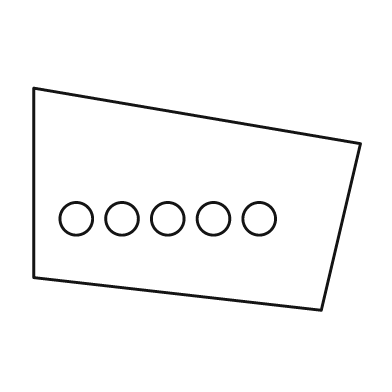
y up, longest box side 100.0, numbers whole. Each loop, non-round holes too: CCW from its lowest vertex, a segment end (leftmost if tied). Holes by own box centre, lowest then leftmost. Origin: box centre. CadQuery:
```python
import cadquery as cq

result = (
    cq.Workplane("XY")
    .moveTo(38.0, -34.0)
    .lineTo(50.0, 17.0)
    .lineTo(-50.0, 34.0)
    .lineTo(-50.0, -24.0)
    .close()
    .moveTo(-37.0, -6.0)
    .circle(5.0)
    .moveTo(-23.0, -6.0)
    .circle(5.0)
    .moveTo(-9.0, -6.0)
    .circle(5.0)
    .moveTo(5.0, -6.0)
    .circle(5.0)
    .moveTo(19.0, -6.0)
    .circle(5.0)
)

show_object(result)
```